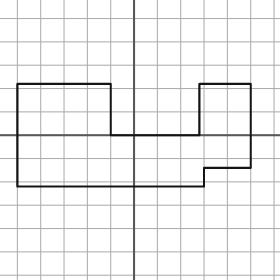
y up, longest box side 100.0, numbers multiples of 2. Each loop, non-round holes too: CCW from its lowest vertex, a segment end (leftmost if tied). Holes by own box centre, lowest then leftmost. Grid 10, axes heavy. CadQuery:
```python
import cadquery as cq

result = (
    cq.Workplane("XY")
    .moveTo(-50.0, -22.0)
    .lineTo(30.0, -22.0)
    .lineTo(30.0, -14.0)
    .lineTo(50.0, -14.0)
    .lineTo(50.0, 22.0)
    .lineTo(28.0, 22.0)
    .lineTo(28.0, 0.0)
    .lineTo(-10.0, 0.0)
    .lineTo(-10.0, 22.0)
    .lineTo(-50.0, 22.0)
    .close()
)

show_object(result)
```